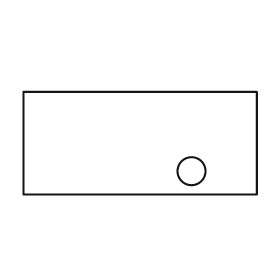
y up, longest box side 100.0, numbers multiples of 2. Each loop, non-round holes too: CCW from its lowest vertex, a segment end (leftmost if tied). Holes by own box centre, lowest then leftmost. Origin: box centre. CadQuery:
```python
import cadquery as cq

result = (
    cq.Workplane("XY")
    .moveTo(-50.0, -22.0)
    .lineTo(50.0, -22.0)
    .lineTo(50.0, 22.0)
    .lineTo(-50.0, 22.0)
    .close()
    .moveTo(22.0, -12.0)
    .circle(6.0)
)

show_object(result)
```